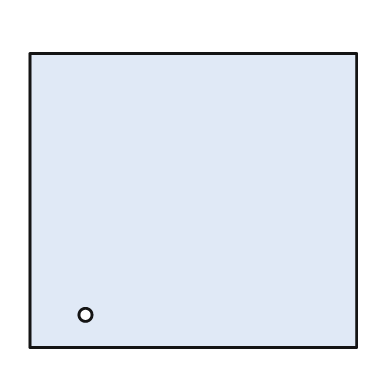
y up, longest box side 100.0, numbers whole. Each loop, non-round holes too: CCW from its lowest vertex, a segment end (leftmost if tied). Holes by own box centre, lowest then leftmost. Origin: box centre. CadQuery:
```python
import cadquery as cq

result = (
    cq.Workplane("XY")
    .moveTo(-50.0, -45.0)
    .lineTo(50.0, -45.0)
    .lineTo(50.0, 45.0)
    .lineTo(-50.0, 45.0)
    .close()
    .moveTo(-33.0, -35.0)
    .circle(2.0)
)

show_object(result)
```